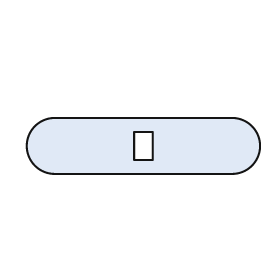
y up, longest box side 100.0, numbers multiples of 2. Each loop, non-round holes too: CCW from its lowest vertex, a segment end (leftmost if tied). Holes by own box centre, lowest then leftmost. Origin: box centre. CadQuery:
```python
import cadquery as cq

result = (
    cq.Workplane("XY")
    .moveTo(-38.0, -12.0)
    .lineTo(38.0, -12.0)
    .threePointArc((50.0, 0.0), (38.0, 12.0))
    .lineTo(-38.0, 12.0)
    .threePointArc((-50.0, 0.0), (-38.0, -12.0))
    .close()
    .moveTo(-4.0, -6.0)
    .lineTo(4.0, -6.0)
    .lineTo(4.0, 6.0)
    .lineTo(-4.0, 6.0)
    .close()
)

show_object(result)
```